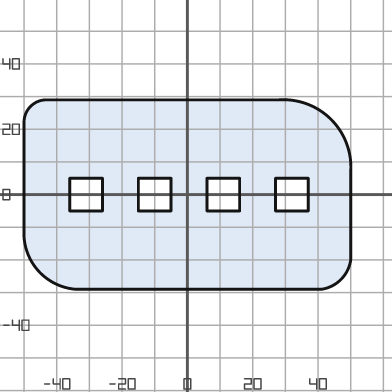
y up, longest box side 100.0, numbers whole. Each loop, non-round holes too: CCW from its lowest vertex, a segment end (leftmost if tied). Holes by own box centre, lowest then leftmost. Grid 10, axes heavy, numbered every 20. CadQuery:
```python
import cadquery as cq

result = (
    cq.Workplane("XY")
    .moveTo(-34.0, -29.0)
    .lineTo(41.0, -29.0)
    .threePointArc((47.0, -26.0), (50.0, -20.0))
    .lineTo(50.0, 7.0)
    .threePointArc((44.0, 23.0), (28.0, 29.0))
    .lineTo(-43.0, 29.0)
    .threePointArc((-48.0, 27.0), (-50.0, 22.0))
    .lineTo(-50.0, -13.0)
    .threePointArc((-45.0, -24.0), (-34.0, -29.0))
    .close()
    .moveTo(-36.0, -5.0)
    .lineTo(-26.0, -5.0)
    .lineTo(-26.0, 5.0)
    .lineTo(-36.0, 5.0)
    .close()
    .moveTo(-15.0, -5.0)
    .lineTo(-5.0, -5.0)
    .lineTo(-5.0, 5.0)
    .lineTo(-15.0, 5.0)
    .close()
    .moveTo(6.0, -5.0)
    .lineTo(16.0, -5.0)
    .lineTo(16.0, 5.0)
    .lineTo(6.0, 5.0)
    .close()
    .moveTo(27.0, -5.0)
    .lineTo(37.0, -5.0)
    .lineTo(37.0, 5.0)
    .lineTo(27.0, 5.0)
    .close()
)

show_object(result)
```